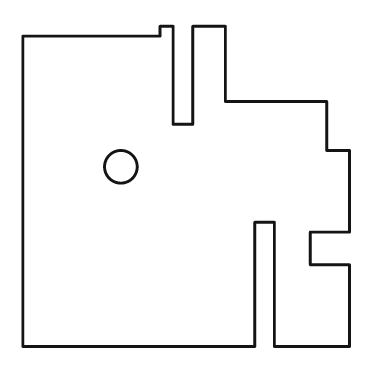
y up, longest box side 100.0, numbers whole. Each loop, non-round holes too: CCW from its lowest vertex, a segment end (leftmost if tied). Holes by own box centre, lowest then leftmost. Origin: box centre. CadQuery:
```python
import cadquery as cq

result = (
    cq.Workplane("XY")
    .moveTo(-50.0, -49.0)
    .lineTo(21.0, -49.0)
    .lineTo(21.0, -11.0)
    .lineTo(27.0, -11.0)
    .lineTo(27.0, -49.0)
    .lineTo(50.0, -49.0)
    .lineTo(50.0, -24.0)
    .lineTo(38.0, -24.0)
    .lineTo(38.0, -14.0)
    .lineTo(50.0, -14.0)
    .lineTo(50.0, 11.0)
    .lineTo(43.0, 11.0)
    .lineTo(43.0, 26.0)
    .lineTo(12.0, 26.0)
    .lineTo(12.0, 49.0)
    .lineTo(2.0, 49.0)
    .lineTo(2.0, 19.0)
    .lineTo(-4.0, 19.0)
    .lineTo(-4.0, 49.0)
    .lineTo(-8.0, 49.0)
    .lineTo(-8.0, 46.0)
    .lineTo(-50.0, 46.0)
    .close()
    .moveTo(-20.0, 6.0)
    .circle(5.0)
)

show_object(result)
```